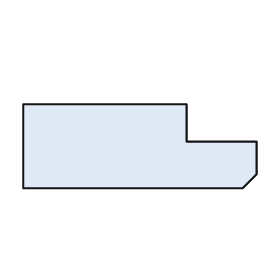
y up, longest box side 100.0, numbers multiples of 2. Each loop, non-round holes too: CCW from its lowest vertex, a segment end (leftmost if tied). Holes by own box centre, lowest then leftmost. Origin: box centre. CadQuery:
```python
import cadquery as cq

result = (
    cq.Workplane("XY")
    .moveTo(-50.0, -18.0)
    .lineTo(44.0, -18.0)
    .lineTo(50.0, -12.0)
    .lineTo(50.0, 2.0)
    .lineTo(20.0, 2.0)
    .lineTo(20.0, 18.0)
    .lineTo(-50.0, 18.0)
    .close()
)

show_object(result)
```